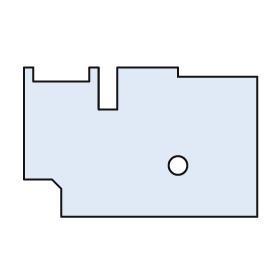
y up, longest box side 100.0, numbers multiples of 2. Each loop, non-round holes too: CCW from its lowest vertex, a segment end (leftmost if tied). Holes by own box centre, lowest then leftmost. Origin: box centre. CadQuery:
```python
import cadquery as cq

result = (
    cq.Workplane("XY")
    .moveTo(-34.0, -32.0)
    .lineTo(50.0, -32.0)
    .lineTo(50.0, 28.0)
    .lineTo(16.0, 28.0)
    .lineTo(16.0, 32.0)
    .lineTo(-10.0, 32.0)
    .lineTo(-10.0, 14.0)
    .lineTo(-18.0, 14.0)
    .lineTo(-18.0, 32.0)
    .lineTo(-22.0, 32.0)
    .lineTo(-22.0, 26.0)
    .lineTo(-46.0, 26.0)
    .lineTo(-46.0, 32.0)
    .lineTo(-50.0, 32.0)
    .lineTo(-50.0, -16.0)
    .lineTo(-38.0, -16.0)
    .lineTo(-34.0, -20.0)
    .close()
    .moveTo(16.0, -10.0)
    .circle(4.0)
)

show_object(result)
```